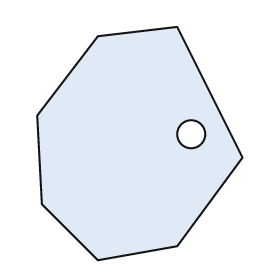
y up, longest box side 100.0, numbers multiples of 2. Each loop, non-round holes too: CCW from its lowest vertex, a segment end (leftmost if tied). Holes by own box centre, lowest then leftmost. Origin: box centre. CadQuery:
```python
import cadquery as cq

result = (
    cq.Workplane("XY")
    .moveTo(-18.0, -50.0)
    .lineTo(16.0, -44.0)
    .lineTo(44.0, -6.0)
    .lineTo(16.0, 50.0)
    .lineTo(-18.0, 46.0)
    .lineTo(-44.0, 12.0)
    .lineTo(-42.0, -26.0)
    .close()
    .moveTo(22.0, 4.0)
    .circle(6.0)
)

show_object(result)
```